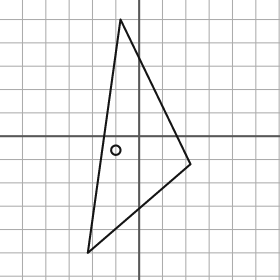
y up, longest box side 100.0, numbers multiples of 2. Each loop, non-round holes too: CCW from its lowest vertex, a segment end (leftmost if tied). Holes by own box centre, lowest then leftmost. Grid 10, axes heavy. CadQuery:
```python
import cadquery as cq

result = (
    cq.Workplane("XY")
    .moveTo(-22.0, -50.0)
    .lineTo(22.0, -12.0)
    .lineTo(-8.0, 50.0)
    .close()
    .moveTo(-10.0, -6.0)
    .circle(2.0)
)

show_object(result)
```